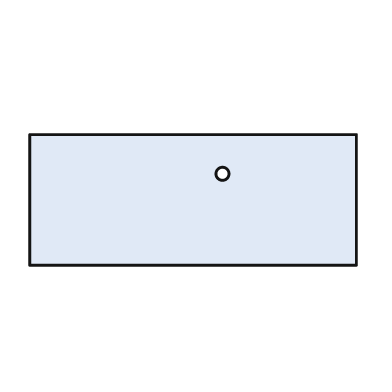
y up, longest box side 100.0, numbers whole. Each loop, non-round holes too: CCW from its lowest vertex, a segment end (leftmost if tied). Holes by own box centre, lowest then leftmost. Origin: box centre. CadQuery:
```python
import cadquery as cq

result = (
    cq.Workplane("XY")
    .moveTo(-50.0, -20.0)
    .lineTo(50.0, -20.0)
    .lineTo(50.0, 20.0)
    .lineTo(-50.0, 20.0)
    .close()
    .moveTo(9.0, 8.0)
    .circle(2.0)
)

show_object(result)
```